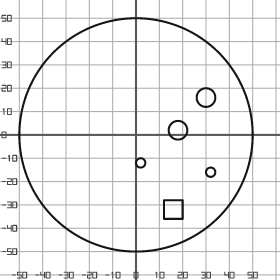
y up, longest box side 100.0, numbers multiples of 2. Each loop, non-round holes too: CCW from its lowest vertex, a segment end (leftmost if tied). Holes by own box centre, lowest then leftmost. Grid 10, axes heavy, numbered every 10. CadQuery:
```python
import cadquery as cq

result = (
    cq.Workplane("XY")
    .moveTo(0.0, 0.0)
    .circle(50.0)
    .moveTo(12.0, -36.0)
    .lineTo(20.0, -36.0)
    .lineTo(20.0, -28.0)
    .lineTo(12.0, -28.0)
    .close()
    .moveTo(32.0, -16.0)
    .circle(2.0)
    .moveTo(2.0, -12.0)
    .circle(2.0)
    .moveTo(18.0, 2.0)
    .circle(4.0)
    .moveTo(30.0, 16.0)
    .circle(4.0)
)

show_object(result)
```